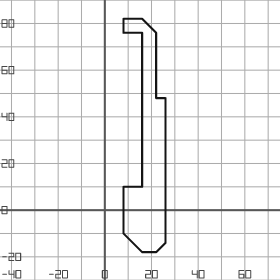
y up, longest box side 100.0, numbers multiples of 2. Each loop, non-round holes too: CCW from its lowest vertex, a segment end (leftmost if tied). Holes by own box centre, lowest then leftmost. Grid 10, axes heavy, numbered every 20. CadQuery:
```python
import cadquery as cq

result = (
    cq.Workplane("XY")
    .moveTo(16.0, -18.0)
    .lineTo(22.0, -18.0)
    .lineTo(26.0, -14.0)
    .lineTo(26.0, 48.0)
    .lineTo(22.0, 48.0)
    .lineTo(22.0, 76.0)
    .lineTo(16.0, 82.0)
    .lineTo(8.0, 82.0)
    .lineTo(8.0, 76.0)
    .lineTo(16.0, 76.0)
    .lineTo(16.0, 10.0)
    .lineTo(8.0, 10.0)
    .lineTo(8.0, -10.0)
    .close()
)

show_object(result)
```